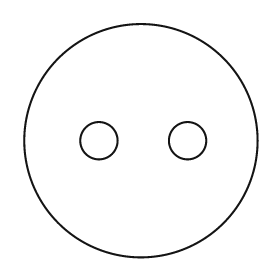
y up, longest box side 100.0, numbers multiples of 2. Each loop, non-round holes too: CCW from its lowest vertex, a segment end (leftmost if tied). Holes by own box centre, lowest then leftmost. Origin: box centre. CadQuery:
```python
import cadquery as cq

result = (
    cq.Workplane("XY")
    .moveTo(0.0, 0.0)
    .circle(50.0)
    .moveTo(-18.0, 0.0)
    .circle(8.0)
    .moveTo(20.0, 0.0)
    .circle(8.0)
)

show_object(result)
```